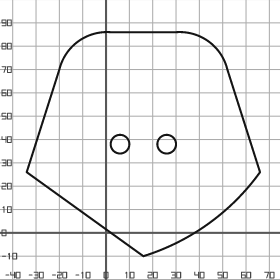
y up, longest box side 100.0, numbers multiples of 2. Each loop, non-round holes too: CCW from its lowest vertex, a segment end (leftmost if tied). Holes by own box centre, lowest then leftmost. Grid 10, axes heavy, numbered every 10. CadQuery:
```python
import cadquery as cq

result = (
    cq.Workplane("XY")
    .moveTo(16.0, -10.0)
    .threePointArc((44.0, 4.0), (66.0, 26.0))
    .lineTo(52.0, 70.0)
    .threePointArc((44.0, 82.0), (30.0, 86.0))
    .lineTo(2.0, 86.0)
    .threePointArc((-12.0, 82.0), (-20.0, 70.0))
    .lineTo(-34.0, 26.0)
    .close()
    .moveTo(6.0, 38.0)
    .circle(4.0)
    .moveTo(26.0, 38.0)
    .circle(4.0)
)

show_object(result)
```